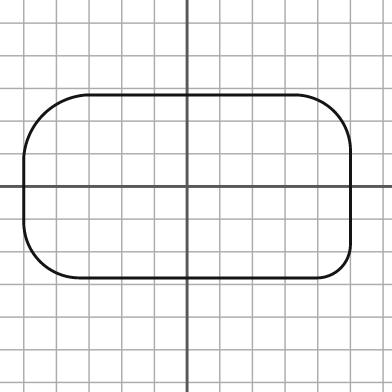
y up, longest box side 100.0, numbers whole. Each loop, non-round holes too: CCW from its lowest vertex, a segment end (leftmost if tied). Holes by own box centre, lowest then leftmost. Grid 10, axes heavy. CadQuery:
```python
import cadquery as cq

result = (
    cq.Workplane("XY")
    .moveTo(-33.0, -28.0)
    .lineTo(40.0, -28.0)
    .threePointArc((47.0, -25.0), (50.0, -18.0))
    .lineTo(50.0, 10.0)
    .threePointArc((45.0, 23.0), (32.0, 28.0))
    .lineTo(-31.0, 28.0)
    .threePointArc((-44.0, 22.0), (-50.0, 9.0))
    .lineTo(-50.0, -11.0)
    .threePointArc((-45.0, -23.0), (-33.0, -28.0))
    .close()
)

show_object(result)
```